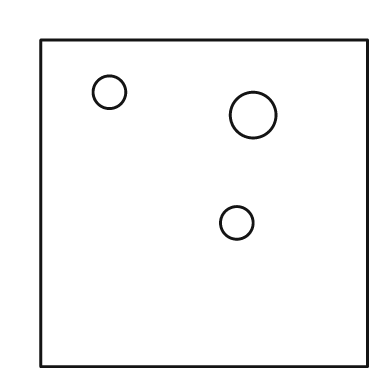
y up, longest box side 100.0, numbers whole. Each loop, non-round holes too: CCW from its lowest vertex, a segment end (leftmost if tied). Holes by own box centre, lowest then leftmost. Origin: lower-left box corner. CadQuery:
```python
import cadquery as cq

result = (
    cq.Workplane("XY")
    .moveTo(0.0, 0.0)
    .lineTo(100.0, 0.0)
    .lineTo(100.0, 100.0)
    .lineTo(0.0, 100.0)
    .close()
    .moveTo(60.0, 44.0)
    .circle(5.0)
    .moveTo(65.0, 77.0)
    .circle(7.0)
    .moveTo(21.0, 84.0)
    .circle(5.0)
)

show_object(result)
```